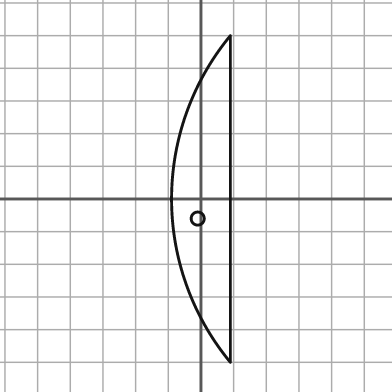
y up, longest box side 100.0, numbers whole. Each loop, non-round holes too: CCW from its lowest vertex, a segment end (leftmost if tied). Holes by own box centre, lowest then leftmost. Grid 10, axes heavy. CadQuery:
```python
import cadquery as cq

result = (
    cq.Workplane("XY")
    .moveTo(9.0, -50.0)
    .lineTo(9.0, 50.0)
    .threePointArc((-9.0, 0.0), (9.0, -50.0))
    .close()
    .moveTo(-1.0, -6.0)
    .circle(2.0)
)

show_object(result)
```